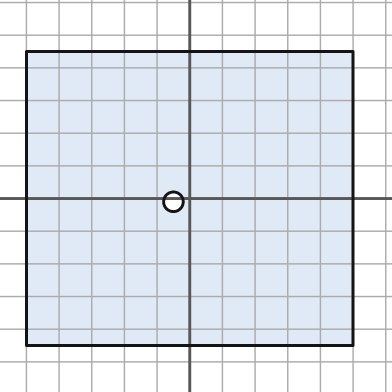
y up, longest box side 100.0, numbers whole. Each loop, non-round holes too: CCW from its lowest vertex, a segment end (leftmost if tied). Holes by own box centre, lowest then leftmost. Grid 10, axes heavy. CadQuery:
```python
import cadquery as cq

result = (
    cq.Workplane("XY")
    .moveTo(-50.0, -45.0)
    .lineTo(50.0, -45.0)
    .lineTo(50.0, 45.0)
    .lineTo(-50.0, 45.0)
    .close()
    .moveTo(-5.0, -1.0)
    .circle(3.0)
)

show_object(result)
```